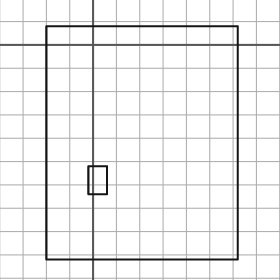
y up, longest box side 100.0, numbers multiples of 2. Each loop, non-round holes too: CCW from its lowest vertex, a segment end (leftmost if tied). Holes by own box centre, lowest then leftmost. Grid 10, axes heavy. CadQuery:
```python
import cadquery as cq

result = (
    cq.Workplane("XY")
    .moveTo(-20.0, -92.0)
    .lineTo(62.0, -92.0)
    .lineTo(62.0, 8.0)
    .lineTo(-20.0, 8.0)
    .close()
    .moveTo(-2.0, -64.0)
    .lineTo(6.0, -64.0)
    .lineTo(6.0, -52.0)
    .lineTo(-2.0, -52.0)
    .close()
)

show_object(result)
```